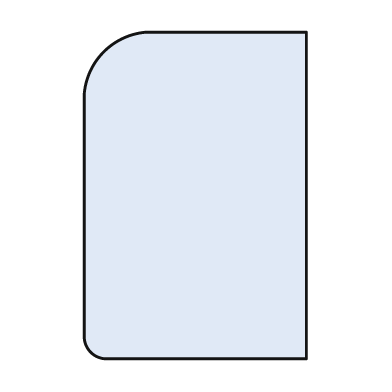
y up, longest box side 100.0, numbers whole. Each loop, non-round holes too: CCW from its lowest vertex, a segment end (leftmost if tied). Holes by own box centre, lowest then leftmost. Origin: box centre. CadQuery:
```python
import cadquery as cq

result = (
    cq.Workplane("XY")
    .moveTo(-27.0, -50.0)
    .lineTo(34.0, -50.0)
    .lineTo(34.0, 50.0)
    .lineTo(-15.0, 50.0)
    .threePointArc((-28.0, 44.0), (-34.0, 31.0))
    .lineTo(-34.0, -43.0)
    .threePointArc((-32.0, -48.0), (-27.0, -50.0))
    .close()
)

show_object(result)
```